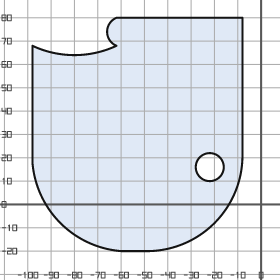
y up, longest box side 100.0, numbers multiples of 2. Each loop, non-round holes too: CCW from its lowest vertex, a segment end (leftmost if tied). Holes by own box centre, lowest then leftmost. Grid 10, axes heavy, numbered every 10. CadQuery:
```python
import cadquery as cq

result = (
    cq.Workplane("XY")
    .moveTo(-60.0, -20.0)
    .lineTo(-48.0, -20.0)
    .threePointArc((-20.0, -8.0), (-8.0, 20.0))
    .lineTo(-8.0, 80.0)
    .lineTo(-62.0, 80.0)
    .threePointArc((-66.0, 74.0), (-62.0, 68.0))
    .threePointArc((-80.0, 64.0), (-98.0, 68.0))
    .lineTo(-98.0, 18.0)
    .threePointArc((-86.0, -8.0), (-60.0, -20.0))
    .close()
    .moveTo(-22.0, 16.0)
    .circle(6.0)
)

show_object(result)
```